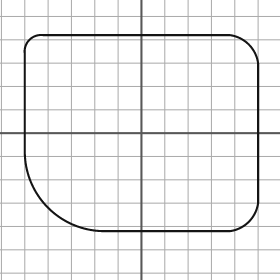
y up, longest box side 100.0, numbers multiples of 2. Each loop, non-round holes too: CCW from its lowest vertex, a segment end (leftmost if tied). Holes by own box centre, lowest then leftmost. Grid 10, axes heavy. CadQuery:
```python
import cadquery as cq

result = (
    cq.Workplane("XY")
    .moveTo(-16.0, -42.0)
    .lineTo(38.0, -42.0)
    .threePointArc((46.0, -38.0), (50.0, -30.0))
    .lineTo(50.0, 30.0)
    .threePointArc((46.0, 38.0), (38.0, 42.0))
    .lineTo(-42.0, 42.0)
    .threePointArc((-48.0, 40.0), (-50.0, 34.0))
    .lineTo(-50.0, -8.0)
    .threePointArc((-40.0, -32.0), (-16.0, -42.0))
    .close()
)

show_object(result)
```